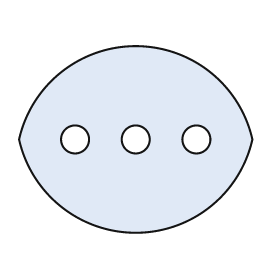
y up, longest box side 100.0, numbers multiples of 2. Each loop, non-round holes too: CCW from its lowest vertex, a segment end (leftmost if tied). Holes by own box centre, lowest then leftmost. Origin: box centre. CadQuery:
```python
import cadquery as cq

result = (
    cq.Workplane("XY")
    .moveTo(-50.0, 0.0)
    .threePointArc((0.0, -40.0), (50.0, 0.0))
    .threePointArc((0.0, 40.0), (-50.0, 0.0))
    .close()
    .moveTo(-26.0, 0.0)
    .circle(6.0)
    .moveTo(0.0, 0.0)
    .circle(6.0)
    .moveTo(26.0, 0.0)
    .circle(6.0)
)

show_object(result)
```